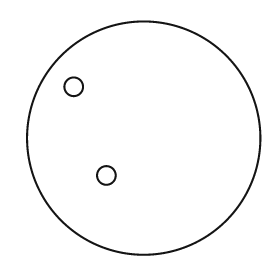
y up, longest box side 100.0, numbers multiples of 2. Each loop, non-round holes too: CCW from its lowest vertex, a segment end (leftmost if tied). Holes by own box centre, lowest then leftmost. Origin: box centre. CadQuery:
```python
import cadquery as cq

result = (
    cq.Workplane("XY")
    .moveTo(0.0, 0.0)
    .circle(50.0)
    .moveTo(-16.0, -16.0)
    .circle(4.0)
    .moveTo(-30.0, 22.0)
    .circle(4.0)
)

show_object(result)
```